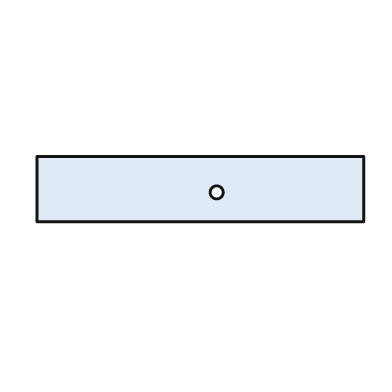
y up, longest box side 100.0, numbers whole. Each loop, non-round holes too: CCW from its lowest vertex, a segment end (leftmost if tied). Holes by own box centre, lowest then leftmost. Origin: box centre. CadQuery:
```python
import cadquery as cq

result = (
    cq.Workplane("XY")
    .moveTo(-50.0, -10.0)
    .lineTo(50.0, -10.0)
    .lineTo(50.0, 10.0)
    .lineTo(-50.0, 10.0)
    .close()
    .moveTo(5.0, -1.0)
    .circle(2.0)
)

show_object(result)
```